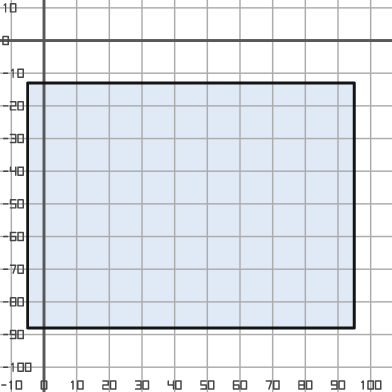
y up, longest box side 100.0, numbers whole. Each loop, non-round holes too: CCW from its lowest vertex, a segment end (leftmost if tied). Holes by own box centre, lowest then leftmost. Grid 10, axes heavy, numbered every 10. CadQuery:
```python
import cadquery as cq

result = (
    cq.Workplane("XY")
    .moveTo(-5.0, -88.0)
    .lineTo(95.0, -88.0)
    .lineTo(95.0, -13.0)
    .lineTo(-5.0, -13.0)
    .close()
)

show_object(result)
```